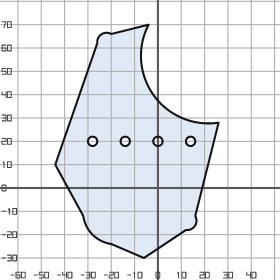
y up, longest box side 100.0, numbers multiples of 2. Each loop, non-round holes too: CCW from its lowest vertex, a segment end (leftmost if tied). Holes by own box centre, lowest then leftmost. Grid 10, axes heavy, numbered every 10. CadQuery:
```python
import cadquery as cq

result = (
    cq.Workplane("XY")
    .moveTo(-6.0, -30.0)
    .lineTo(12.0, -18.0)
    .threePointArc((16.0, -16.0), (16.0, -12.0))
    .lineTo(26.0, 28.0)
    .threePointArc((-2.0, 40.0), (-4.0, 70.0))
    .lineTo(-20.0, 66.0)
    .threePointArc((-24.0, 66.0), (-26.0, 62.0))
    .lineTo(-44.0, 10.0)
    .lineTo(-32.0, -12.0)
    .threePointArc((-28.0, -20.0), (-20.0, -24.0))
    .close()
    .moveTo(-28.0, 20.0)
    .circle(2.0)
    .moveTo(-14.0, 20.0)
    .circle(2.0)
    .moveTo(0.0, 20.0)
    .circle(2.0)
    .moveTo(14.0, 20.0)
    .circle(2.0)
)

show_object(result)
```